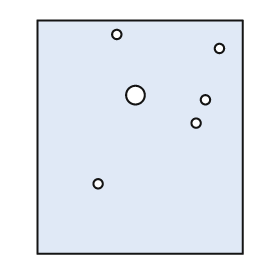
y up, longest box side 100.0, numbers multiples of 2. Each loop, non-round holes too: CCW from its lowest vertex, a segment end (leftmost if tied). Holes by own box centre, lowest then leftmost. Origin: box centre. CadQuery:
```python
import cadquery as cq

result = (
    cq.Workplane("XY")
    .moveTo(-44.0, -50.0)
    .lineTo(44.0, -50.0)
    .lineTo(44.0, 50.0)
    .lineTo(-44.0, 50.0)
    .close()
    .moveTo(-18.0, -20.0)
    .circle(2.0)
    .moveTo(24.0, 6.0)
    .circle(2.0)
    .moveTo(28.0, 16.0)
    .circle(2.0)
    .moveTo(-2.0, 18.0)
    .circle(4.0)
    .moveTo(34.0, 38.0)
    .circle(2.0)
    .moveTo(-10.0, 44.0)
    .circle(2.0)
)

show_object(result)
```